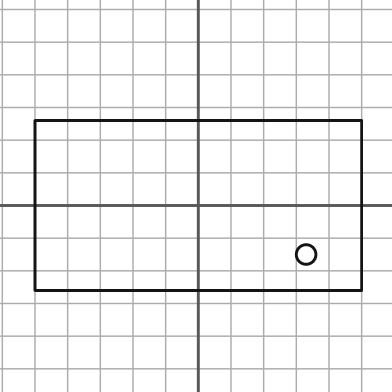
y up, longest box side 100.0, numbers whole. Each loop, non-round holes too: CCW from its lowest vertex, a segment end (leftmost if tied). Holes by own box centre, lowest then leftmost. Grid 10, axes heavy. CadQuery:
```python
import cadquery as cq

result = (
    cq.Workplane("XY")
    .moveTo(-50.0, -26.0)
    .lineTo(50.0, -26.0)
    .lineTo(50.0, 26.0)
    .lineTo(-50.0, 26.0)
    .close()
    .moveTo(33.0, -15.0)
    .circle(3.0)
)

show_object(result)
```